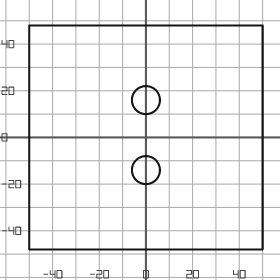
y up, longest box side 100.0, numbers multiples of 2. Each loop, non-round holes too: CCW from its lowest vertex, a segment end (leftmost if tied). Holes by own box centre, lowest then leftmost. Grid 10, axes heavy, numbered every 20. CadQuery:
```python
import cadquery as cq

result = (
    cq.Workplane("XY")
    .moveTo(-50.0, -48.0)
    .lineTo(50.0, -48.0)
    .lineTo(50.0, 48.0)
    .lineTo(-50.0, 48.0)
    .close()
    .moveTo(0.0, -14.0)
    .circle(6.0)
    .moveTo(0.0, 16.0)
    .circle(6.0)
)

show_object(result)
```